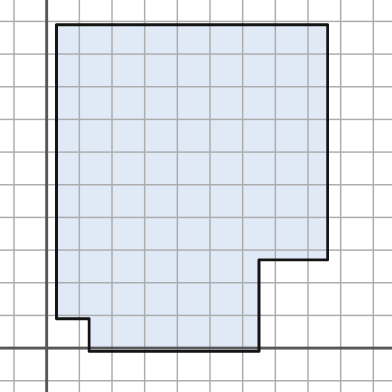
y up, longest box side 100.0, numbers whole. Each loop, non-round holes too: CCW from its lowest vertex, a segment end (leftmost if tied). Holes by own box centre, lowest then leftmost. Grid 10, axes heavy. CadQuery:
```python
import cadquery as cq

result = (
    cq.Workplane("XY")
    .moveTo(13.0, -1.0)
    .lineTo(65.0, -1.0)
    .lineTo(65.0, 27.0)
    .lineTo(86.0, 27.0)
    .lineTo(86.0, 99.0)
    .lineTo(3.0, 99.0)
    .lineTo(3.0, 9.0)
    .lineTo(13.0, 9.0)
    .close()
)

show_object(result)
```